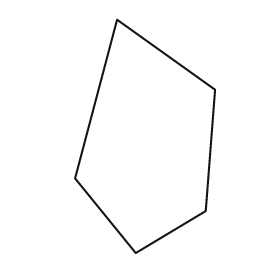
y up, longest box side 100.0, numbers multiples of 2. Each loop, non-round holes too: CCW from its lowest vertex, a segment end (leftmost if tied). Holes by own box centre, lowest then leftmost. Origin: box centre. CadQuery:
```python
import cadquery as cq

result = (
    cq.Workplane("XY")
    .moveTo(-4.0, -50.0)
    .lineTo(26.0, -32.0)
    .lineTo(30.0, 20.0)
    .lineTo(-12.0, 50.0)
    .lineTo(-30.0, -18.0)
    .close()
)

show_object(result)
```